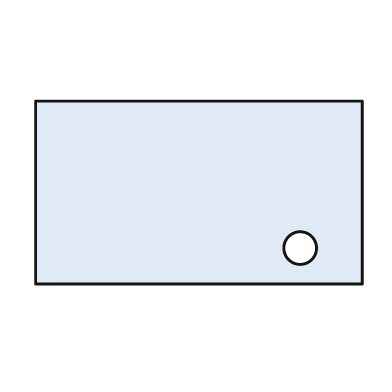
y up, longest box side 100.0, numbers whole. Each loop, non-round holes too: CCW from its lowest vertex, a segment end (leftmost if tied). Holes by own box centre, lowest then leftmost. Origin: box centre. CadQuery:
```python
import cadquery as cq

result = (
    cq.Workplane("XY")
    .moveTo(-50.0, -28.0)
    .lineTo(50.0, -28.0)
    .lineTo(50.0, 28.0)
    .lineTo(-50.0, 28.0)
    .close()
    .moveTo(31.0, -17.0)
    .circle(5.0)
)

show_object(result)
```